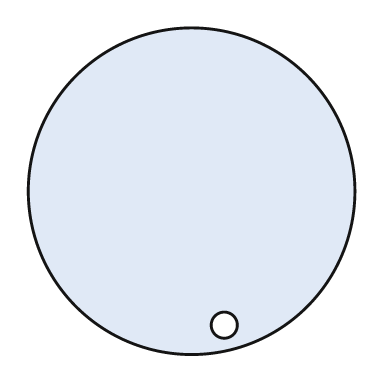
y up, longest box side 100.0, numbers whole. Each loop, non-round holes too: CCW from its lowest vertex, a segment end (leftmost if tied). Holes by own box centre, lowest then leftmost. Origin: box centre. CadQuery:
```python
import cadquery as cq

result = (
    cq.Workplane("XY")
    .moveTo(0.0, 0.0)
    .circle(50.0)
    .moveTo(10.0, -41.0)
    .circle(4.0)
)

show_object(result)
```